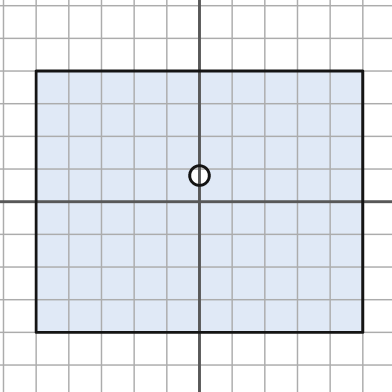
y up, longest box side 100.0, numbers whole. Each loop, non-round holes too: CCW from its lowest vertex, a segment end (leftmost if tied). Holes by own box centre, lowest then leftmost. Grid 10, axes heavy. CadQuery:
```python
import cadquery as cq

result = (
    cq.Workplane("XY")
    .moveTo(-50.0, -40.0)
    .lineTo(50.0, -40.0)
    .lineTo(50.0, 40.0)
    .lineTo(-50.0, 40.0)
    .close()
    .moveTo(0.0, 8.0)
    .circle(3.0)
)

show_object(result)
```